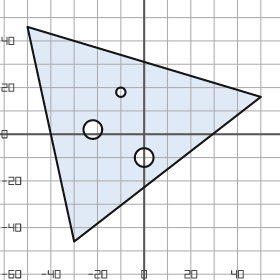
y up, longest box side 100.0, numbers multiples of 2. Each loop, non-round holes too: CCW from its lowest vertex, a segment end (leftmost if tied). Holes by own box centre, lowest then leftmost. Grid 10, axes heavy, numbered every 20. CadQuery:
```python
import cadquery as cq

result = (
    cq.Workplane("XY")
    .moveTo(-30.0, -46.0)
    .lineTo(50.0, 16.0)
    .lineTo(-50.0, 46.0)
    .close()
    .moveTo(0.0, -10.0)
    .circle(4.0)
    .moveTo(-22.0, 2.0)
    .circle(4.0)
    .moveTo(-10.0, 18.0)
    .circle(2.0)
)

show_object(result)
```